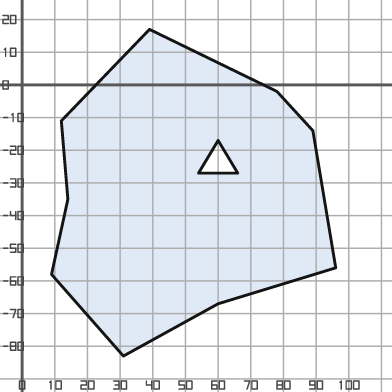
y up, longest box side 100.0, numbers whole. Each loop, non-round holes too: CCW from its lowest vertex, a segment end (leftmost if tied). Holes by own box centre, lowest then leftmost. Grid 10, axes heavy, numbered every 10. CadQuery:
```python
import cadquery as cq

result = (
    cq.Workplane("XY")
    .moveTo(31.0, -83.0)
    .lineTo(60.0, -67.0)
    .lineTo(96.0, -56.0)
    .lineTo(89.0, -14.0)
    .lineTo(78.0, -2.0)
    .lineTo(39.0, 17.0)
    .lineTo(12.0, -11.0)
    .lineTo(14.0, -35.0)
    .lineTo(9.0, -58.0)
    .close()
    .moveTo(54.0, -27.0)
    .lineTo(66.0, -27.0)
    .lineTo(60.0, -17.0)
    .close()
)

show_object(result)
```